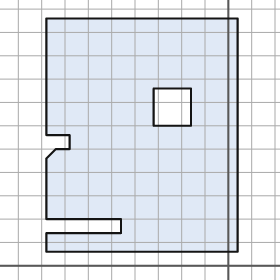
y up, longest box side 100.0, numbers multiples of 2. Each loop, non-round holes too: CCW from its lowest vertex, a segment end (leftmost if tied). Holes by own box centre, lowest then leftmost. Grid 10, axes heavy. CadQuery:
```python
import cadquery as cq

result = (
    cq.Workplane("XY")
    .moveTo(-78.0, 6.0)
    .lineTo(4.0, 6.0)
    .lineTo(4.0, 106.0)
    .lineTo(-78.0, 106.0)
    .lineTo(-78.0, 56.0)
    .lineTo(-68.0, 56.0)
    .lineTo(-68.0, 50.0)
    .lineTo(-74.0, 50.0)
    .lineTo(-78.0, 46.0)
    .lineTo(-78.0, 20.0)
    .lineTo(-46.0, 20.0)
    .lineTo(-46.0, 14.0)
    .lineTo(-78.0, 14.0)
    .close()
    .moveTo(-32.0, 60.0)
    .lineTo(-16.0, 60.0)
    .lineTo(-16.0, 76.0)
    .lineTo(-32.0, 76.0)
    .close()
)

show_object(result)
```